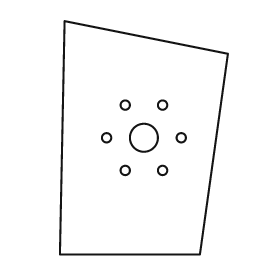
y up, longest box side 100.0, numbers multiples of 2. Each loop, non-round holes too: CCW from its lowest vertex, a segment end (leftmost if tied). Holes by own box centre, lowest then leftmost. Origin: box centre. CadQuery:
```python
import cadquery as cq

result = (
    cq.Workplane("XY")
    .moveTo(-36.0, -50.0)
    .lineTo(24.0, -50.0)
    .lineTo(36.0, 36.0)
    .lineTo(-34.0, 50.0)
    .close()
    .moveTo(-8.0, -14.0)
    .circle(2.0)
    .moveTo(8.0, -14.0)
    .circle(2.0)
    .moveTo(-16.0, 0.0)
    .circle(2.0)
    .moveTo(0.0, 0.0)
    .circle(6.0)
    .moveTo(16.0, 0.0)
    .circle(2.0)
    .moveTo(-8.0, 14.0)
    .circle(2.0)
    .moveTo(8.0, 14.0)
    .circle(2.0)
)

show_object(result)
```